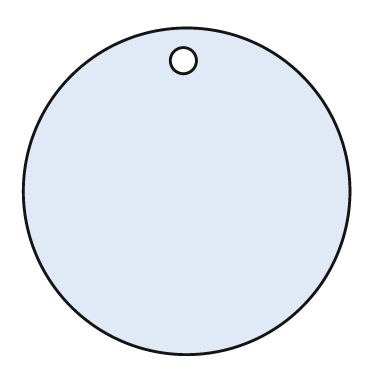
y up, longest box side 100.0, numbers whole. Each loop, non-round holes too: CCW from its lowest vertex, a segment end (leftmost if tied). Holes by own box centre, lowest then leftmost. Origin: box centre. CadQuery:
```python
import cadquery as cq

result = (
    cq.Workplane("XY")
    .moveTo(0.0, 0.0)
    .circle(50.0)
    .moveTo(-1.0, 40.0)
    .circle(4.0)
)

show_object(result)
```